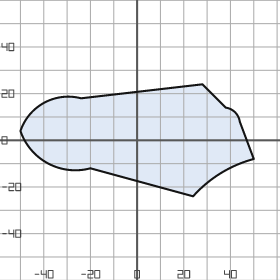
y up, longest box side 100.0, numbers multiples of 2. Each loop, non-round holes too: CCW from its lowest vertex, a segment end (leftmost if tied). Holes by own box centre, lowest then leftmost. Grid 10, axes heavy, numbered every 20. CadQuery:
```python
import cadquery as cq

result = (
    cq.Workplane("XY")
    .moveTo(24.0, -24.0)
    .threePointArc((36.0, -14.0), (50.0, -8.0))
    .lineTo(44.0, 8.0)
    .threePointArc((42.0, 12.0), (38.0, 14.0))
    .lineTo(28.0, 24.0)
    .lineTo(-24.0, 18.0)
    .threePointArc((-40.0, 16.0), (-50.0, 4.0))
    .threePointArc((-38.0, -10.0), (-20.0, -12.0))
    .close()
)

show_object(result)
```